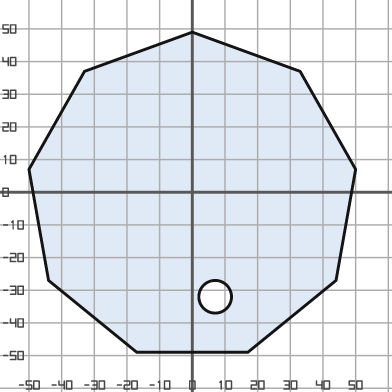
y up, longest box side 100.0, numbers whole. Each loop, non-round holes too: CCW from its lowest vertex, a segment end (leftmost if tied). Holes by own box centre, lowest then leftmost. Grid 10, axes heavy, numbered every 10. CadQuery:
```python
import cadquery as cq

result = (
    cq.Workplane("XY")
    .moveTo(-17.0, -49.0)
    .lineTo(17.0, -49.0)
    .lineTo(44.0, -27.0)
    .lineTo(50.0, 7.0)
    .lineTo(33.0, 37.0)
    .lineTo(0.0, 49.0)
    .lineTo(-33.0, 37.0)
    .lineTo(-50.0, 7.0)
    .lineTo(-44.0, -27.0)
    .close()
    .moveTo(7.0, -32.0)
    .circle(5.0)
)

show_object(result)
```